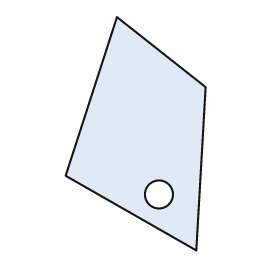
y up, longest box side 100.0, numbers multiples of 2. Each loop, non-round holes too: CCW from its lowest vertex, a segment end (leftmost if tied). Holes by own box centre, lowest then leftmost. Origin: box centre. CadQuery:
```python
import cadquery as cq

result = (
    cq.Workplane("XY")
    .moveTo(26.0, -50.0)
    .lineTo(30.0, 20.0)
    .lineTo(-8.0, 50.0)
    .lineTo(-30.0, -18.0)
    .close()
    .moveTo(10.0, -26.0)
    .circle(6.0)
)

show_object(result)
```